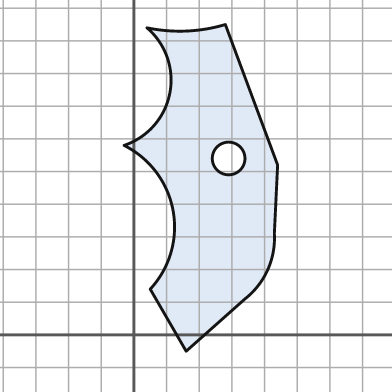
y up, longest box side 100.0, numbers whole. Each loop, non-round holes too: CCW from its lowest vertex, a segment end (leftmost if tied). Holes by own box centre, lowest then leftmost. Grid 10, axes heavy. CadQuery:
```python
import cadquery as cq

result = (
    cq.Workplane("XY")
    .moveTo(16.0, -5.0)
    .lineTo(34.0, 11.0)
    .threePointArc((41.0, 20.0), (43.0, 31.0))
    .lineTo(44.0, 52.0)
    .lineTo(28.0, 95.0)
    .threePointArc((16.0, 93.0), (4.0, 94.0))
    .threePointArc((11.0, 74.0), (-3.0, 58.0))
    .threePointArc((12.0, 38.0), (5.0, 14.0))
    .close()
    .moveTo(29.0, 54.0)
    .circle(5.0)
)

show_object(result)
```